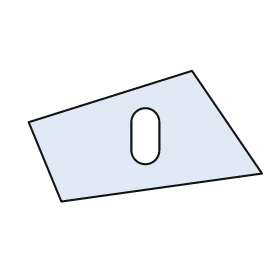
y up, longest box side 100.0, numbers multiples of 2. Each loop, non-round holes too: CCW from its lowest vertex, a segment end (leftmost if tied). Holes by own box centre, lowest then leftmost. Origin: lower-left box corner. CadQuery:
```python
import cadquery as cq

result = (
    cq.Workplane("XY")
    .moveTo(14.0, 0.0)
    .lineTo(100.0, 12.0)
    .lineTo(70.0, 56.0)
    .lineTo(0.0, 34.0)
    .close()
    .moveTo(44.0, 22.0)
    .threePointArc((50.0, 16.0), (56.0, 22.0))
    .lineTo(56.0, 34.0)
    .threePointArc((50.0, 40.0), (44.0, 34.0))
    .close()
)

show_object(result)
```